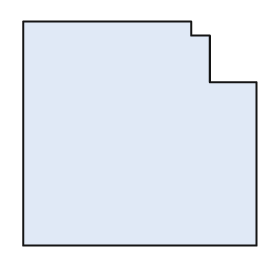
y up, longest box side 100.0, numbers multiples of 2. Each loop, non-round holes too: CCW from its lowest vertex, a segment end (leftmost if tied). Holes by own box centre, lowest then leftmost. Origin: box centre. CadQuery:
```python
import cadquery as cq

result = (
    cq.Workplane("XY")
    .moveTo(-50.0, -48.0)
    .lineTo(50.0, -48.0)
    .lineTo(50.0, 22.0)
    .lineTo(30.0, 22.0)
    .lineTo(30.0, 42.0)
    .lineTo(22.0, 42.0)
    .lineTo(22.0, 48.0)
    .lineTo(-50.0, 48.0)
    .close()
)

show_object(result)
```